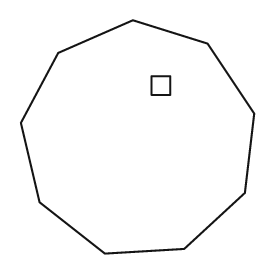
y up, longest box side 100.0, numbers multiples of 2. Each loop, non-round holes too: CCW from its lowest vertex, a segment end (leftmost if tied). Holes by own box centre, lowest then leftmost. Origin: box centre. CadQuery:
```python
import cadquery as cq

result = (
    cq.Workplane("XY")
    .moveTo(-14.0, -50.0)
    .lineTo(20.0, -48.0)
    .lineTo(46.0, -24.0)
    .lineTo(50.0, 10.0)
    .lineTo(30.0, 40.0)
    .lineTo(-2.0, 50.0)
    .lineTo(-34.0, 36.0)
    .lineTo(-50.0, 6.0)
    .lineTo(-42.0, -28.0)
    .close()
    .moveTo(6.0, 18.0)
    .lineTo(14.0, 18.0)
    .lineTo(14.0, 26.0)
    .lineTo(6.0, 26.0)
    .close()
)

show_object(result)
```